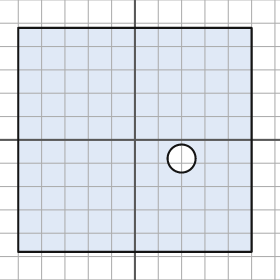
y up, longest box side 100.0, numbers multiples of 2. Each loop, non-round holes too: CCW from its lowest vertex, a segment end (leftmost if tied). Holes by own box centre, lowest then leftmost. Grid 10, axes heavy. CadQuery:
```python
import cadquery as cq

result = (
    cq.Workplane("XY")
    .moveTo(-50.0, -48.0)
    .lineTo(50.0, -48.0)
    .lineTo(50.0, 48.0)
    .lineTo(-50.0, 48.0)
    .close()
    .moveTo(20.0, -8.0)
    .circle(6.0)
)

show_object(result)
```